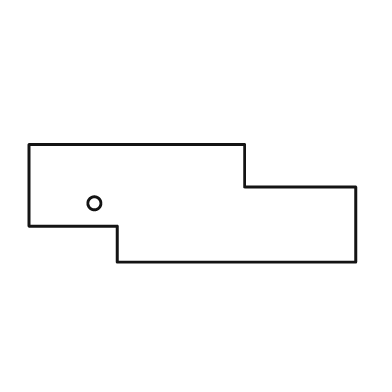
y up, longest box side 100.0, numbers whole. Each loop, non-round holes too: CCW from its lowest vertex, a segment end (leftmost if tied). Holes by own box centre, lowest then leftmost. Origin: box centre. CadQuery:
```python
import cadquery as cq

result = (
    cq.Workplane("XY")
    .moveTo(-23.0, -18.0)
    .lineTo(50.0, -18.0)
    .lineTo(50.0, 5.0)
    .lineTo(16.0, 5.0)
    .lineTo(16.0, 18.0)
    .lineTo(-50.0, 18.0)
    .lineTo(-50.0, -7.0)
    .lineTo(-23.0, -7.0)
    .close()
    .moveTo(-30.0, 0.0)
    .circle(2.0)
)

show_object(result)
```